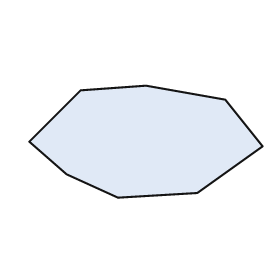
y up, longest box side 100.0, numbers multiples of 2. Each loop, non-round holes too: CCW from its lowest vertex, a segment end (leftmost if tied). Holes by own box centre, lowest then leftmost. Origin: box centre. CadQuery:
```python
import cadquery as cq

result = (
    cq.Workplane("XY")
    .moveTo(-12.0, -24.0)
    .lineTo(22.0, -22.0)
    .lineTo(50.0, -2.0)
    .lineTo(34.0, 18.0)
    .lineTo(0.0, 24.0)
    .lineTo(-28.0, 22.0)
    .lineTo(-50.0, 0.0)
    .lineTo(-34.0, -14.0)
    .close()
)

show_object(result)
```